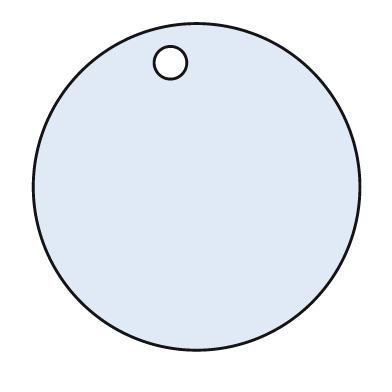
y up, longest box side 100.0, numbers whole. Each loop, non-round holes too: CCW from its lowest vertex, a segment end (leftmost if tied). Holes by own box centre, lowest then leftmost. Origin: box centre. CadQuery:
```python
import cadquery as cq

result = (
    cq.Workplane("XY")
    .moveTo(0.0, 0.0)
    .circle(50.0)
    .moveTo(-8.0, 38.0)
    .circle(5.0)
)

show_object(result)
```